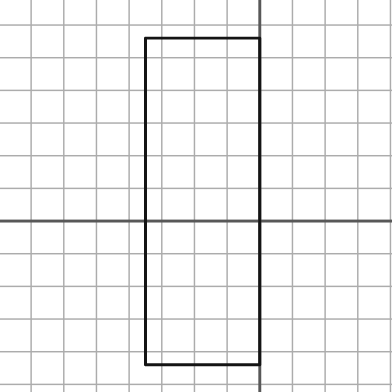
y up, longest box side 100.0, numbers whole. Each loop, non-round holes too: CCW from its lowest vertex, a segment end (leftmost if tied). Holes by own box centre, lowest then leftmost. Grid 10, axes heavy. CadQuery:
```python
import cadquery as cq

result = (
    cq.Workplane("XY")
    .moveTo(-35.0, -44.0)
    .lineTo(0.0, -44.0)
    .lineTo(0.0, 56.0)
    .lineTo(-35.0, 56.0)
    .close()
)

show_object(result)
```